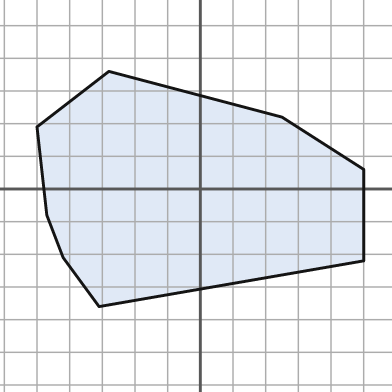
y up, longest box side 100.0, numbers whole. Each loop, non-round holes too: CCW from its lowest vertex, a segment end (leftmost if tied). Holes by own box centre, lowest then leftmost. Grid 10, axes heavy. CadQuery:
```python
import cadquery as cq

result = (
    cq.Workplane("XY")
    .moveTo(-31.0, -36.0)
    .lineTo(50.0, -22.0)
    .lineTo(50.0, 6.0)
    .lineTo(25.0, 22.0)
    .lineTo(-28.0, 36.0)
    .lineTo(-50.0, 19.0)
    .lineTo(-47.0, -8.0)
    .lineTo(-42.0, -21.0)
    .close()
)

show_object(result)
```